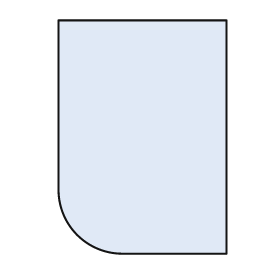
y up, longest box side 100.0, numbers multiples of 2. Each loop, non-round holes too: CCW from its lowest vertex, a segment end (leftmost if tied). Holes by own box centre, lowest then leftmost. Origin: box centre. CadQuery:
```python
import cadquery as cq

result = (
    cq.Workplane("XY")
    .moveTo(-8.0, -50.0)
    .lineTo(36.0, -50.0)
    .lineTo(36.0, 50.0)
    .lineTo(-36.0, 50.0)
    .lineTo(-36.0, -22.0)
    .threePointArc((-28.0, -42.0), (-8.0, -50.0))
    .close()
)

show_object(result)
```